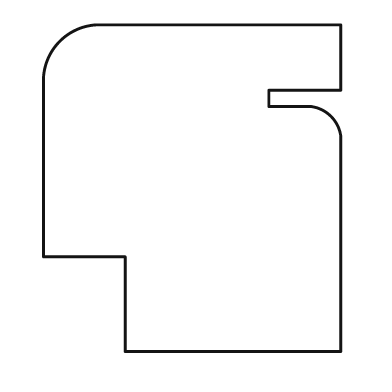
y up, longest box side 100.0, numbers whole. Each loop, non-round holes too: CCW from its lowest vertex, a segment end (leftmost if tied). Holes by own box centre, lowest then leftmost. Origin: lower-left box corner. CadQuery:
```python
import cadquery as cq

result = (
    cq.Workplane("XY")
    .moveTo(25.0, 0.0)
    .lineTo(91.0, 0.0)
    .lineTo(91.0, 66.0)
    .threePointArc((88.0, 72.0), (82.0, 75.0))
    .lineTo(69.0, 75.0)
    .lineTo(69.0, 80.0)
    .lineTo(91.0, 80.0)
    .lineTo(91.0, 100.0)
    .lineTo(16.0, 100.0)
    .threePointArc((5.0, 95.0), (0.0, 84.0))
    .lineTo(0.0, 29.0)
    .lineTo(25.0, 29.0)
    .close()
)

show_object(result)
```